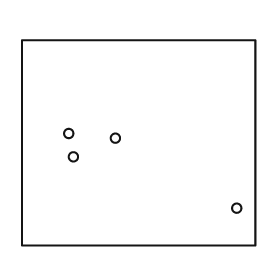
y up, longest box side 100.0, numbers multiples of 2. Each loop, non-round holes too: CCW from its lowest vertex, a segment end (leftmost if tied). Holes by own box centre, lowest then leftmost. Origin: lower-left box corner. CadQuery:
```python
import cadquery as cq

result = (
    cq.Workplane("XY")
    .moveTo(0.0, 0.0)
    .lineTo(100.0, 0.0)
    .lineTo(100.0, 88.0)
    .lineTo(0.0, 88.0)
    .close()
    .moveTo(92.0, 16.0)
    .circle(2.0)
    .moveTo(22.0, 38.0)
    .circle(2.0)
    .moveTo(40.0, 46.0)
    .circle(2.0)
    .moveTo(20.0, 48.0)
    .circle(2.0)
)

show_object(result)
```